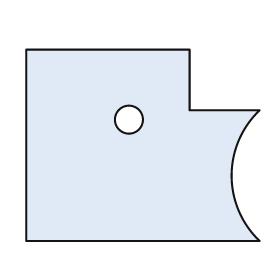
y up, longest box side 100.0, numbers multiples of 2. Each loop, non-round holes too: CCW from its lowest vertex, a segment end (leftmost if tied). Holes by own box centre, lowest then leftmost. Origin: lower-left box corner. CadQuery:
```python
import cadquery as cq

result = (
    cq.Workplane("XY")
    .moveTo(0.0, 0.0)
    .lineTo(100.0, 0.0)
    .threePointArc((88.0, 28.0), (100.0, 56.0))
    .lineTo(70.0, 56.0)
    .lineTo(70.0, 82.0)
    .lineTo(0.0, 82.0)
    .close()
    .moveTo(44.0, 52.0)
    .circle(6.0)
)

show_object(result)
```